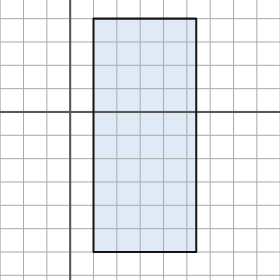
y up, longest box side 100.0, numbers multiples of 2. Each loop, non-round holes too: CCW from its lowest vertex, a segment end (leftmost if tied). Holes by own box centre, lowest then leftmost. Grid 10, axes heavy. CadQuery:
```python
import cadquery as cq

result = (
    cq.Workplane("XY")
    .moveTo(10.0, -60.0)
    .lineTo(54.0, -60.0)
    .lineTo(54.0, 40.0)
    .lineTo(10.0, 40.0)
    .close()
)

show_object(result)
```